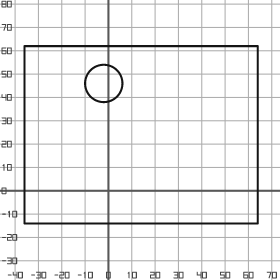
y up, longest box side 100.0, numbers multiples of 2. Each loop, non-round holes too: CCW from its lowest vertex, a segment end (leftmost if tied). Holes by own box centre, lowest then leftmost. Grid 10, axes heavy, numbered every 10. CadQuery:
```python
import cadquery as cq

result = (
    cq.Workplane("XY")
    .moveTo(-36.0, -14.0)
    .lineTo(64.0, -14.0)
    .lineTo(64.0, 62.0)
    .lineTo(-36.0, 62.0)
    .close()
    .moveTo(-2.0, 46.0)
    .circle(8.0)
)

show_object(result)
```